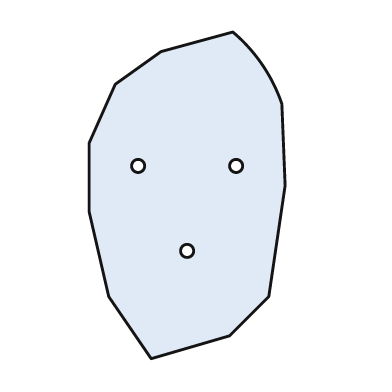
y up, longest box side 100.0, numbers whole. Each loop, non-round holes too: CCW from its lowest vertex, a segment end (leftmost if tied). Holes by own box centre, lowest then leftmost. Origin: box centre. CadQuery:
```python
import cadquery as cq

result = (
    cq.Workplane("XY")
    .moveTo(-11.0, -50.0)
    .lineTo(13.0, -43.0)
    .lineTo(25.0, -31.0)
    .lineTo(30.0, 3.0)
    .lineTo(29.0, 28.0)
    .threePointArc((23.0, 40.0), (14.0, 50.0))
    .lineTo(-8.0, 44.0)
    .lineTo(-22.0, 34.0)
    .lineTo(-30.0, 16.0)
    .lineTo(-30.0, -5.0)
    .lineTo(-24.0, -31.0)
    .close()
    .moveTo(0.0, -17.0)
    .circle(2.0)
    .moveTo(-15.0, 9.0)
    .circle(2.0)
    .moveTo(15.0, 9.0)
    .circle(2.0)
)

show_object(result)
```